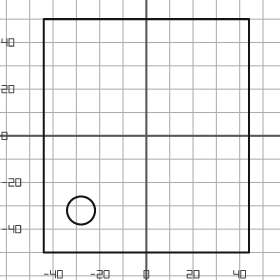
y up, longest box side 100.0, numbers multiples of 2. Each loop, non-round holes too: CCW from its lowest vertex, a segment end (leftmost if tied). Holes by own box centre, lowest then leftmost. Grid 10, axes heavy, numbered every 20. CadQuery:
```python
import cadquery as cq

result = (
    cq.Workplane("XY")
    .moveTo(-44.0, -50.0)
    .lineTo(44.0, -50.0)
    .lineTo(44.0, 50.0)
    .lineTo(-44.0, 50.0)
    .close()
    .moveTo(-28.0, -32.0)
    .circle(6.0)
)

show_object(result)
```